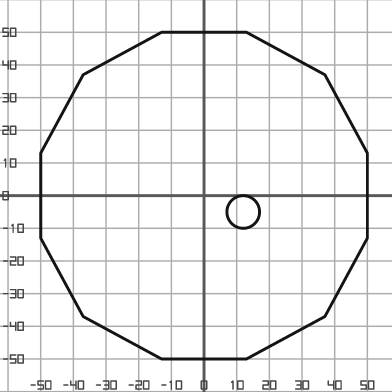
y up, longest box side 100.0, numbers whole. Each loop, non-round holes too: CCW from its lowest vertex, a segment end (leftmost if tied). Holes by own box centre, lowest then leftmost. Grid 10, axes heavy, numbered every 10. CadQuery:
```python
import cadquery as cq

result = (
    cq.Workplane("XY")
    .moveTo(-13.0, -50.0)
    .lineTo(13.0, -50.0)
    .lineTo(37.0, -37.0)
    .lineTo(50.0, -13.0)
    .lineTo(50.0, 13.0)
    .lineTo(37.0, 37.0)
    .lineTo(13.0, 50.0)
    .lineTo(-13.0, 50.0)
    .lineTo(-37.0, 37.0)
    .lineTo(-50.0, 13.0)
    .lineTo(-50.0, -13.0)
    .lineTo(-37.0, -37.0)
    .close()
    .moveTo(12.0, -5.0)
    .circle(5.0)
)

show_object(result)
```